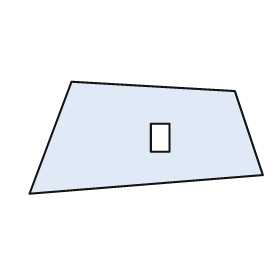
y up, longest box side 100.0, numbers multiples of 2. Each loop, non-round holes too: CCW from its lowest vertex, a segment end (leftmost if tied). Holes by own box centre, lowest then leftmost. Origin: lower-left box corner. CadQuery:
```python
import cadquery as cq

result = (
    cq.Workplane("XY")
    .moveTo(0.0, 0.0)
    .lineTo(100.0, 8.0)
    .lineTo(88.0, 44.0)
    .lineTo(18.0, 48.0)
    .close()
    .moveTo(52.0, 18.0)
    .lineTo(60.0, 18.0)
    .lineTo(60.0, 30.0)
    .lineTo(52.0, 30.0)
    .close()
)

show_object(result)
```